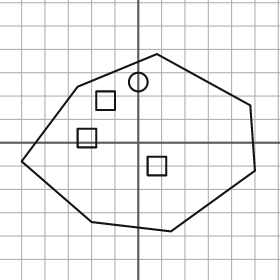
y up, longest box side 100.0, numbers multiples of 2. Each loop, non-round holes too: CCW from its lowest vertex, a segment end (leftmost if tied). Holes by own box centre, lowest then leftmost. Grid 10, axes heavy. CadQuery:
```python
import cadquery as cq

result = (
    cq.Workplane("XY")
    .moveTo(14.0, -38.0)
    .lineTo(50.0, -12.0)
    .lineTo(48.0, 16.0)
    .lineTo(8.0, 38.0)
    .lineTo(-26.0, 24.0)
    .lineTo(-50.0, -8.0)
    .lineTo(-20.0, -34.0)
    .close()
    .moveTo(4.0, -14.0)
    .lineTo(12.0, -14.0)
    .lineTo(12.0, -6.0)
    .lineTo(4.0, -6.0)
    .close()
    .moveTo(-26.0, -2.0)
    .lineTo(-18.0, -2.0)
    .lineTo(-18.0, 6.0)
    .lineTo(-26.0, 6.0)
    .close()
    .moveTo(-18.0, 14.0)
    .lineTo(-10.0, 14.0)
    .lineTo(-10.0, 22.0)
    .lineTo(-18.0, 22.0)
    .close()
    .moveTo(0.0, 26.0)
    .circle(4.0)
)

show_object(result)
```